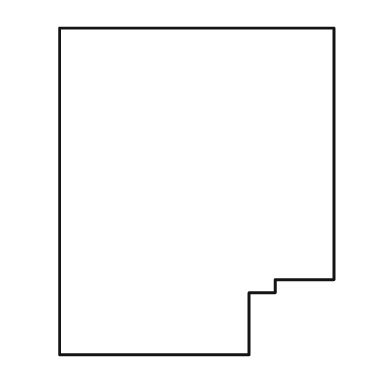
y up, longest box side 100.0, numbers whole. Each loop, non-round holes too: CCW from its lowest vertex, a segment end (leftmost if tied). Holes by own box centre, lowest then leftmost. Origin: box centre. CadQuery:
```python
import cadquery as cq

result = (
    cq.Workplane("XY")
    .moveTo(-42.0, -50.0)
    .lineTo(16.0, -50.0)
    .lineTo(16.0, -31.0)
    .lineTo(24.0, -31.0)
    .lineTo(24.0, -27.0)
    .lineTo(42.0, -27.0)
    .lineTo(42.0, 50.0)
    .lineTo(-42.0, 50.0)
    .close()
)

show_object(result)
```